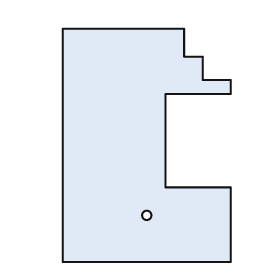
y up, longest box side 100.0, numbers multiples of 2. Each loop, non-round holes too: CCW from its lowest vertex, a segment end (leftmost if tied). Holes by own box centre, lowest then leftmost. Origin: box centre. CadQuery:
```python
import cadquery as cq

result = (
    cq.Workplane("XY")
    .moveTo(-36.0, -50.0)
    .lineTo(36.0, -50.0)
    .lineTo(36.0, -18.0)
    .lineTo(8.0, -18.0)
    .lineTo(8.0, 22.0)
    .lineTo(36.0, 22.0)
    .lineTo(36.0, 28.0)
    .lineTo(24.0, 28.0)
    .lineTo(24.0, 38.0)
    .lineTo(16.0, 38.0)
    .lineTo(16.0, 50.0)
    .lineTo(-36.0, 50.0)
    .close()
    .moveTo(0.0, -30.0)
    .circle(2.0)
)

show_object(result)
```